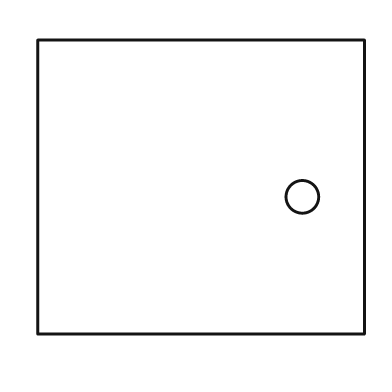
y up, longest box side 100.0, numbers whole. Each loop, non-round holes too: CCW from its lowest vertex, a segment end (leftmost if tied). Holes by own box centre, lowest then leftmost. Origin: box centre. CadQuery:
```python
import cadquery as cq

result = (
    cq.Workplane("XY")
    .moveTo(-50.0, -45.0)
    .lineTo(50.0, -45.0)
    .lineTo(50.0, 45.0)
    .lineTo(-50.0, 45.0)
    .close()
    .moveTo(31.0, -3.0)
    .circle(5.0)
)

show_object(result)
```